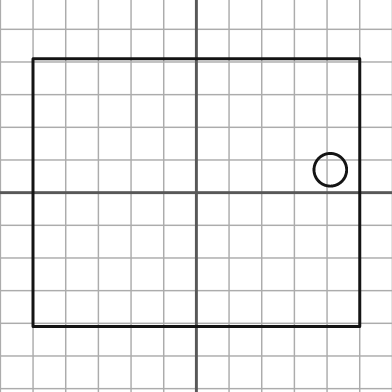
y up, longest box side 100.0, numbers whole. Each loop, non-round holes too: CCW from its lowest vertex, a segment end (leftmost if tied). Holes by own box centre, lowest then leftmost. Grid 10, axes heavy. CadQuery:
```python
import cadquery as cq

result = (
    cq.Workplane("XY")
    .moveTo(-50.0, -41.0)
    .lineTo(50.0, -41.0)
    .lineTo(50.0, 41.0)
    .lineTo(-50.0, 41.0)
    .close()
    .moveTo(41.0, 7.0)
    .circle(5.0)
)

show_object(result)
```